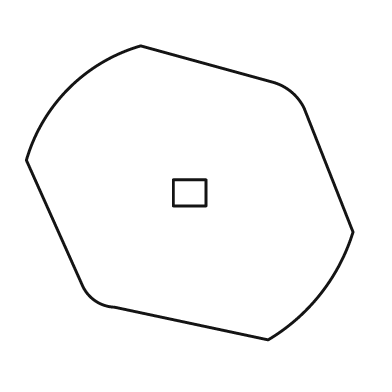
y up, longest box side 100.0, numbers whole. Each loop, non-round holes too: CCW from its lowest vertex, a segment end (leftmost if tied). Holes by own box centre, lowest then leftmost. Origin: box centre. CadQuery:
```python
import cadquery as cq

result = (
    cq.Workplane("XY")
    .moveTo(24.0, -45.0)
    .threePointArc((40.0, -31.0), (50.0, -12.0))
    .lineTo(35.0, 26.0)
    .threePointArc((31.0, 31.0), (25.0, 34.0))
    .lineTo(-15.0, 45.0)
    .threePointArc((-37.0, 32.0), (-50.0, 10.0))
    .lineTo(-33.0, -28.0)
    .threePointArc((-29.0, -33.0), (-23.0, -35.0))
    .close()
    .moveTo(-5.0, -4.0)
    .lineTo(5.0, -4.0)
    .lineTo(5.0, 4.0)
    .lineTo(-5.0, 4.0)
    .close()
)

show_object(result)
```